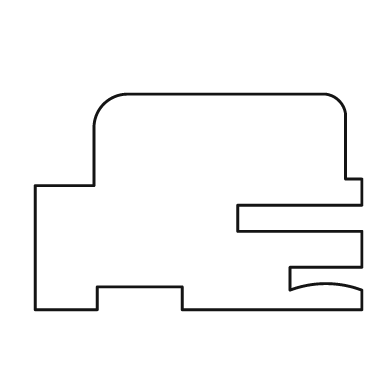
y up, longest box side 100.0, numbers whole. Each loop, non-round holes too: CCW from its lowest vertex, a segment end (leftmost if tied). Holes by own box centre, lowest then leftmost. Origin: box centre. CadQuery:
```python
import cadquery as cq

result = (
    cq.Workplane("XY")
    .moveTo(-50.0, -33.0)
    .lineTo(-31.0, -33.0)
    .lineTo(-31.0, -26.0)
    .lineTo(-5.0, -26.0)
    .lineTo(-5.0, -33.0)
    .lineTo(50.0, -33.0)
    .lineTo(50.0, -27.0)
    .threePointArc((39.0, -25.0), (28.0, -27.0))
    .lineTo(28.0, -20.0)
    .lineTo(50.0, -20.0)
    .lineTo(50.0, -9.0)
    .lineTo(12.0, -9.0)
    .lineTo(12.0, -1.0)
    .lineTo(50.0, -1.0)
    .lineTo(50.0, 7.0)
    .lineTo(45.0, 7.0)
    .lineTo(45.0, 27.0)
    .threePointArc((43.0, 31.0), (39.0, 33.0))
    .lineTo(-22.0, 33.0)
    .threePointArc((-29.0, 30.0), (-32.0, 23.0))
    .lineTo(-32.0, 5.0)
    .lineTo(-50.0, 5.0)
    .close()
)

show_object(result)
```